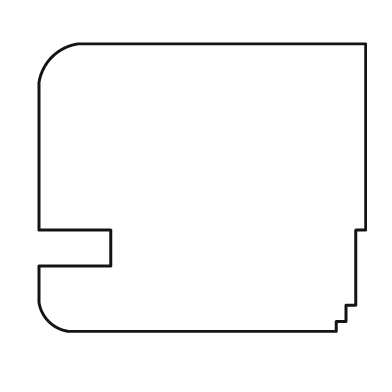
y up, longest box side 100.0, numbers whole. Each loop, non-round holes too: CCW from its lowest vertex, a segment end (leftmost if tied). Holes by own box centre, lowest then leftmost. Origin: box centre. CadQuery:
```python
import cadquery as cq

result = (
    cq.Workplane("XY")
    .moveTo(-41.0, -44.0)
    .lineTo(41.0, -44.0)
    .lineTo(41.0, -41.0)
    .lineTo(44.0, -41.0)
    .lineTo(44.0, -36.0)
    .lineTo(47.0, -36.0)
    .lineTo(47.0, -13.0)
    .lineTo(50.0, -13.0)
    .lineTo(50.0, 44.0)
    .lineTo(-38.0, 44.0)
    .threePointArc((-46.0, 40.0), (-50.0, 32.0))
    .lineTo(-50.0, -13.0)
    .lineTo(-28.0, -13.0)
    .lineTo(-28.0, -24.0)
    .lineTo(-50.0, -24.0)
    .lineTo(-50.0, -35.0)
    .threePointArc((-47.0, -41.0), (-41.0, -44.0))
    .close()
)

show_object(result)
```